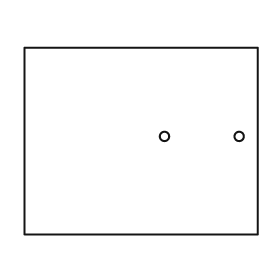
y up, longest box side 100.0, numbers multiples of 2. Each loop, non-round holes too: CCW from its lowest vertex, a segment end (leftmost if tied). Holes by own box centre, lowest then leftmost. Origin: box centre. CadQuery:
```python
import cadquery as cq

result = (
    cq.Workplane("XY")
    .moveTo(-50.0, -40.0)
    .lineTo(50.0, -40.0)
    .lineTo(50.0, 40.0)
    .lineTo(-50.0, 40.0)
    .close()
    .moveTo(10.0, 2.0)
    .circle(2.0)
    .moveTo(42.0, 2.0)
    .circle(2.0)
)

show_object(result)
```